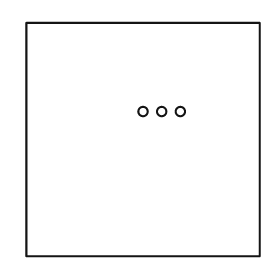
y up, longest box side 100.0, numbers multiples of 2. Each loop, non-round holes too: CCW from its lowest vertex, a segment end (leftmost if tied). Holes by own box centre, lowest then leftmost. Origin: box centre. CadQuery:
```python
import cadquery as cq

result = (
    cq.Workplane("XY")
    .moveTo(-50.0, -50.0)
    .lineTo(50.0, -50.0)
    .lineTo(50.0, 50.0)
    .lineTo(-50.0, 50.0)
    .close()
    .moveTo(0.0, 12.0)
    .circle(2.0)
    .moveTo(8.0, 12.0)
    .circle(2.0)
    .moveTo(16.0, 12.0)
    .circle(2.0)
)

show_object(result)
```